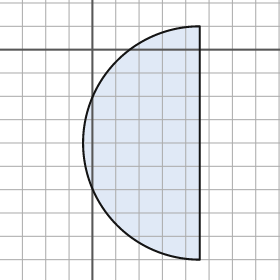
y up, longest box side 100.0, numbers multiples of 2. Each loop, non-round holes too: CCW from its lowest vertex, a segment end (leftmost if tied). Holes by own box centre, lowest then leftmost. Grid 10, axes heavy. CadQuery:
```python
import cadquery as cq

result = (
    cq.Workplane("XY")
    .moveTo(46.0, -90.0)
    .lineTo(46.0, 10.0)
    .threePointArc((-4.0, -40.0), (46.0, -90.0))
    .close()
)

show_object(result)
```